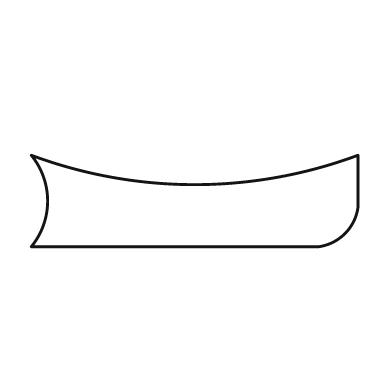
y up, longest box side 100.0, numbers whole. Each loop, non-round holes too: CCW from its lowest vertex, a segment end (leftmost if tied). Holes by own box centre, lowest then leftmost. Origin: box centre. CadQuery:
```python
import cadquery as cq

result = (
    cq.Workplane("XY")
    .moveTo(-50.0, -14.0)
    .lineTo(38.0, -14.0)
    .threePointArc((46.0, -10.0), (50.0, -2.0))
    .lineTo(50.0, 14.0)
    .threePointArc((0.0, 5.0), (-50.0, 14.0))
    .threePointArc((-45.0, 0.0), (-50.0, -14.0))
    .close()
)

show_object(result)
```